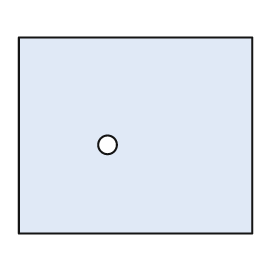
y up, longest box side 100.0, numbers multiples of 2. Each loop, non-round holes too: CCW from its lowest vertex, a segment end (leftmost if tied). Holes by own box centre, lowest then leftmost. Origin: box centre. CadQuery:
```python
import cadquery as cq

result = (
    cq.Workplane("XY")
    .moveTo(-50.0, -42.0)
    .lineTo(50.0, -42.0)
    .lineTo(50.0, 42.0)
    .lineTo(-50.0, 42.0)
    .close()
    .moveTo(-12.0, -4.0)
    .circle(4.0)
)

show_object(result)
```